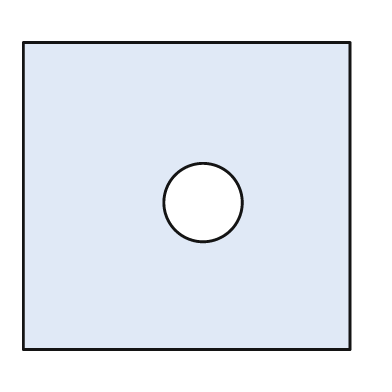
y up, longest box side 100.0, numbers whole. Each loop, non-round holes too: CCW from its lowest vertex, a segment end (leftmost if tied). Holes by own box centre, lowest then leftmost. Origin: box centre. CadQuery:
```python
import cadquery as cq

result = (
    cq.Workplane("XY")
    .moveTo(-50.0, -47.0)
    .lineTo(50.0, -47.0)
    .lineTo(50.0, 47.0)
    .lineTo(-50.0, 47.0)
    .close()
    .moveTo(5.0, -2.0)
    .circle(12.0)
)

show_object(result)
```